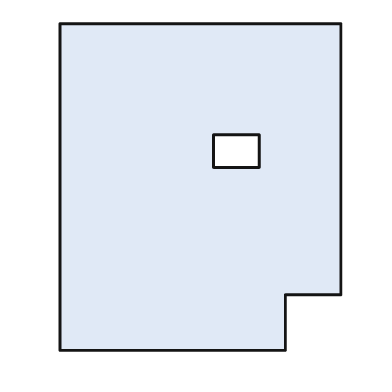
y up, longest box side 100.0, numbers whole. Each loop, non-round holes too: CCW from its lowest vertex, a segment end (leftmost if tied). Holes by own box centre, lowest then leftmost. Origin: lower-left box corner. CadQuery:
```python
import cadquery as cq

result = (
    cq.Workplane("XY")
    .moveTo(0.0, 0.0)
    .lineTo(69.0, 0.0)
    .lineTo(69.0, 17.0)
    .lineTo(86.0, 17.0)
    .lineTo(86.0, 100.0)
    .lineTo(0.0, 100.0)
    .close()
    .moveTo(47.0, 56.0)
    .lineTo(61.0, 56.0)
    .lineTo(61.0, 66.0)
    .lineTo(47.0, 66.0)
    .close()
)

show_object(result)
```